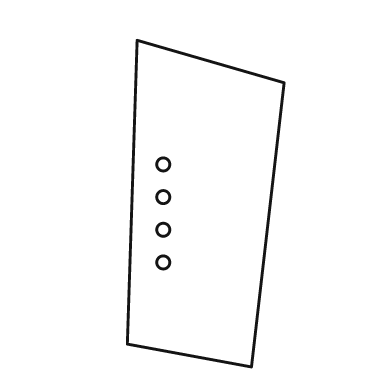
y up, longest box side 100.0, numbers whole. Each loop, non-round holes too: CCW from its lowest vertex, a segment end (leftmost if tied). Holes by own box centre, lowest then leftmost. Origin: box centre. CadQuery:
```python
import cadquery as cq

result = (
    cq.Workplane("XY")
    .moveTo(14.0, -50.0)
    .lineTo(24.0, 37.0)
    .lineTo(-21.0, 50.0)
    .lineTo(-24.0, -43.0)
    .close()
    .moveTo(-13.0, -18.0)
    .circle(2.0)
    .moveTo(-13.0, -8.0)
    .circle(2.0)
    .moveTo(-13.0, 2.0)
    .circle(2.0)
    .moveTo(-13.0, 12.0)
    .circle(2.0)
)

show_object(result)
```